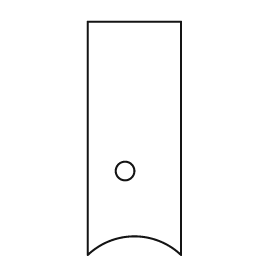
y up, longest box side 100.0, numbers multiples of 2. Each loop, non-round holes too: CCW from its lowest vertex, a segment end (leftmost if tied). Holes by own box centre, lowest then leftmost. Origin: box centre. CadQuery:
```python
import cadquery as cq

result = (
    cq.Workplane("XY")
    .moveTo(-20.0, -50.0)
    .threePointArc((0.0, -42.0), (20.0, -50.0))
    .lineTo(20.0, 50.0)
    .lineTo(-20.0, 50.0)
    .close()
    .moveTo(-4.0, -14.0)
    .circle(4.0)
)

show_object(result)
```